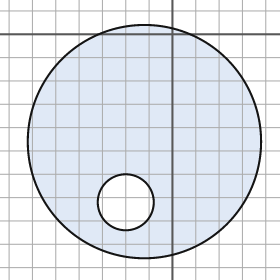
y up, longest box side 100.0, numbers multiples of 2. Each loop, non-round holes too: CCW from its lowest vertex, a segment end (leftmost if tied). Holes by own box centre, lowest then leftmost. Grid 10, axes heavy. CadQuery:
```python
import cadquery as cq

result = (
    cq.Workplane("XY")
    .moveTo(-12.0, -46.0)
    .circle(50.0)
    .moveTo(-20.0, -72.0)
    .circle(12.0)
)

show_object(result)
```